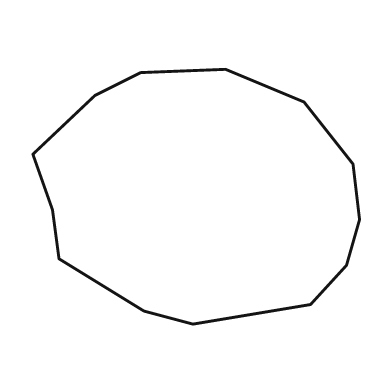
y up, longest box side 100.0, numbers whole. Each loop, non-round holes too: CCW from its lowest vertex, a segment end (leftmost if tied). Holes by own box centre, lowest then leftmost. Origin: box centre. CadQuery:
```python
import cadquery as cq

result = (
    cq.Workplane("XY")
    .moveTo(-1.0, -39.0)
    .lineTo(35.0, -33.0)
    .lineTo(46.0, -21.0)
    .lineTo(50.0, -7.0)
    .lineTo(48.0, 10.0)
    .lineTo(33.0, 29.0)
    .lineTo(9.0, 39.0)
    .lineTo(-17.0, 38.0)
    .lineTo(-31.0, 31.0)
    .lineTo(-50.0, 13.0)
    .lineTo(-44.0, -4.0)
    .lineTo(-42.0, -19.0)
    .lineTo(-16.0, -35.0)
    .close()
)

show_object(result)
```